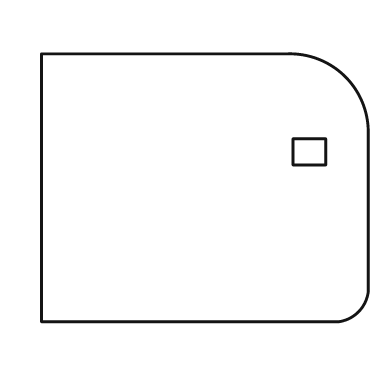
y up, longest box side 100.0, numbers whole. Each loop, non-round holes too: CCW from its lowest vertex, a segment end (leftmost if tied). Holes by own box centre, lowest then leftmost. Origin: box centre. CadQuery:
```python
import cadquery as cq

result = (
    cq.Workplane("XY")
    .moveTo(-50.0, -41.0)
    .lineTo(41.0, -41.0)
    .threePointArc((47.0, -38.0), (50.0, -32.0))
    .lineTo(50.0, 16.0)
    .threePointArc((43.0, 34.0), (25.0, 41.0))
    .lineTo(-50.0, 41.0)
    .close()
    .moveTo(27.0, 7.0)
    .lineTo(37.0, 7.0)
    .lineTo(37.0, 15.0)
    .lineTo(27.0, 15.0)
    .close()
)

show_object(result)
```